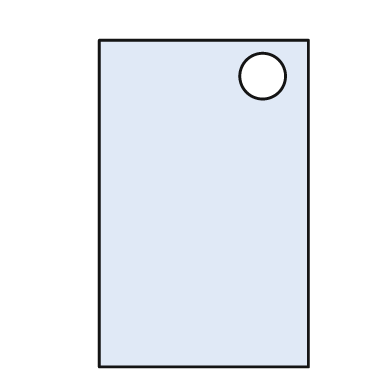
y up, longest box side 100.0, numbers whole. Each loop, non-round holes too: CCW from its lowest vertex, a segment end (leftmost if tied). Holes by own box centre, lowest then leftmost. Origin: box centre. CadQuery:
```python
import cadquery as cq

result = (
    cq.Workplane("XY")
    .moveTo(-32.0, -50.0)
    .lineTo(32.0, -50.0)
    .lineTo(32.0, 50.0)
    .lineTo(-32.0, 50.0)
    .close()
    .moveTo(18.0, 39.0)
    .circle(7.0)
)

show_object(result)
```